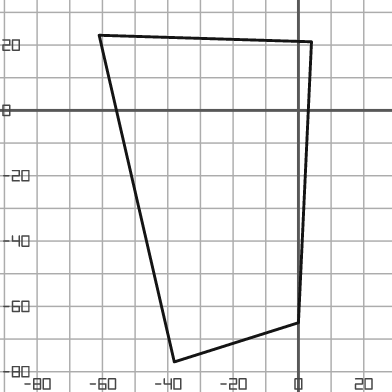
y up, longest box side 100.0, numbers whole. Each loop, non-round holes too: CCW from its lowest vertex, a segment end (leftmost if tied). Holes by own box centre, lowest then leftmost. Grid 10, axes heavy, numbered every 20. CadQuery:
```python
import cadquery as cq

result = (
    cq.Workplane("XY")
    .moveTo(-38.0, -77.0)
    .lineTo(0.0, -65.0)
    .lineTo(4.0, 21.0)
    .lineTo(-61.0, 23.0)
    .close()
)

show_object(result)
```